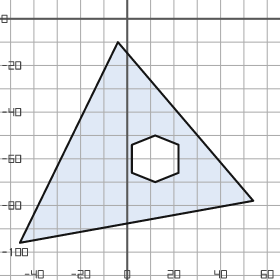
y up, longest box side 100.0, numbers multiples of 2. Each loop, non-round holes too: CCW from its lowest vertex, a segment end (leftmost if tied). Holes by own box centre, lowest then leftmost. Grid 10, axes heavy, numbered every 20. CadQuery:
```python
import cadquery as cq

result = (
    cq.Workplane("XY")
    .moveTo(-46.0, -96.0)
    .lineTo(54.0, -78.0)
    .lineTo(-4.0, -10.0)
    .close()
    .moveTo(12.0, -70.0)
    .lineTo(22.0, -66.0)
    .lineTo(22.0, -54.0)
    .lineTo(12.0, -50.0)
    .lineTo(2.0, -54.0)
    .lineTo(2.0, -66.0)
    .close()
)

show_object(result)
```